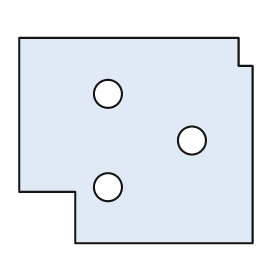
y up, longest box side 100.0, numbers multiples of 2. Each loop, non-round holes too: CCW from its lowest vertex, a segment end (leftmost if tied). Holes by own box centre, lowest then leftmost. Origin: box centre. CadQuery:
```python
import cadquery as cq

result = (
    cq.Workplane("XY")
    .moveTo(-26.0, -44.0)
    .lineTo(50.0, -44.0)
    .lineTo(50.0, 32.0)
    .lineTo(44.0, 32.0)
    .lineTo(44.0, 44.0)
    .lineTo(-50.0, 44.0)
    .lineTo(-50.0, -22.0)
    .lineTo(-26.0, -22.0)
    .close()
    .moveTo(-12.0, -20.0)
    .circle(6.0)
    .moveTo(24.0, 0.0)
    .circle(6.0)
    .moveTo(-12.0, 20.0)
    .circle(6.0)
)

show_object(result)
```